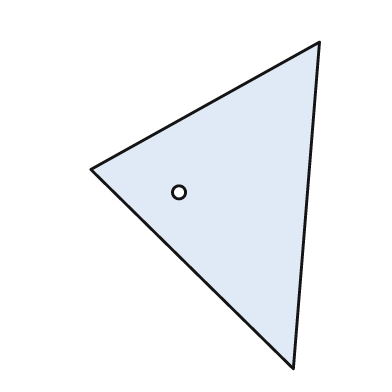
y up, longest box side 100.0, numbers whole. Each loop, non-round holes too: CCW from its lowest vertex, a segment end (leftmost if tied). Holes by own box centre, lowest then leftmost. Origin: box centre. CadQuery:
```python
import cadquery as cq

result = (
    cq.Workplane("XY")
    .moveTo(27.0, -50.0)
    .lineTo(35.0, 50.0)
    .lineTo(-35.0, 11.0)
    .close()
    .moveTo(-8.0, 4.0)
    .circle(2.0)
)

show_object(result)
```